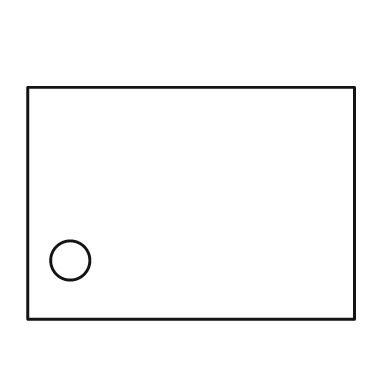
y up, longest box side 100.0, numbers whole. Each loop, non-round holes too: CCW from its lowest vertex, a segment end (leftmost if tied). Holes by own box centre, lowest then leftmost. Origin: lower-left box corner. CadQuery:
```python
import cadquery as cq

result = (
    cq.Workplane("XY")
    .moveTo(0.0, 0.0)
    .lineTo(100.0, 0.0)
    .lineTo(100.0, 71.0)
    .lineTo(0.0, 71.0)
    .close()
    .moveTo(13.0, 18.0)
    .circle(6.0)
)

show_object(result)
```